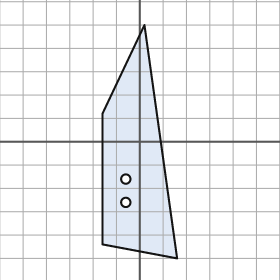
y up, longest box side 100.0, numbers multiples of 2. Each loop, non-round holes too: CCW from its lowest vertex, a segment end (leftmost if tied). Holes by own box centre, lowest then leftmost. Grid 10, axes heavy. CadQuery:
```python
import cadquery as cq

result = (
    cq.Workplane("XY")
    .moveTo(16.0, -50.0)
    .lineTo(2.0, 50.0)
    .lineTo(-16.0, 12.0)
    .lineTo(-16.0, -44.0)
    .close()
    .moveTo(-6.0, -26.0)
    .circle(2.0)
    .moveTo(-6.0, -16.0)
    .circle(2.0)
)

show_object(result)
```